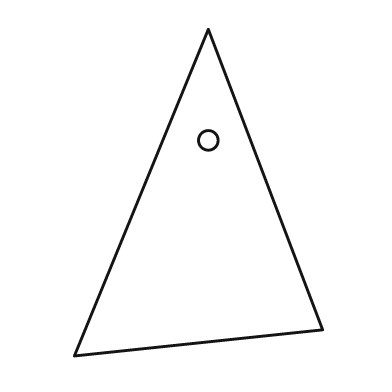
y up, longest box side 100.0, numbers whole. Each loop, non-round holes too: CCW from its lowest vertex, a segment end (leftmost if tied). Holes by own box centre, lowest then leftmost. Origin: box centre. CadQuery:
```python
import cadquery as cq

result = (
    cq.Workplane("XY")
    .moveTo(-38.0, -50.0)
    .lineTo(38.0, -42.0)
    .lineTo(3.0, 50.0)
    .close()
    .moveTo(3.0, 16.0)
    .circle(3.0)
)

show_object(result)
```